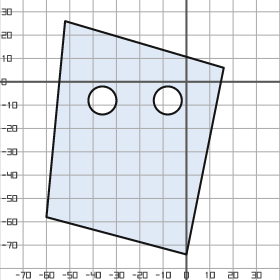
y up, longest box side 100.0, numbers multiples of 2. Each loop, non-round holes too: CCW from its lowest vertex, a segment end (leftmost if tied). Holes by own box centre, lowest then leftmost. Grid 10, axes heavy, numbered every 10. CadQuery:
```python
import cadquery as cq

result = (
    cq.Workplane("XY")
    .moveTo(0.0, -74.0)
    .lineTo(16.0, 6.0)
    .lineTo(-52.0, 26.0)
    .lineTo(-60.0, -58.0)
    .close()
    .moveTo(-36.0, -8.0)
    .circle(6.0)
    .moveTo(-8.0, -8.0)
    .circle(6.0)
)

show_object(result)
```